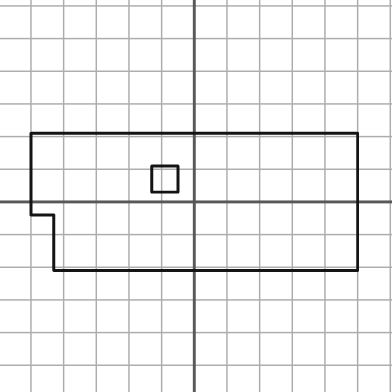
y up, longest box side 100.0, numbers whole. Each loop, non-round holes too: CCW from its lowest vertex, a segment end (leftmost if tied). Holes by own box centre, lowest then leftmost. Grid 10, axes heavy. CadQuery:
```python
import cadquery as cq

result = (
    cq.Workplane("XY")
    .moveTo(-43.0, -21.0)
    .lineTo(50.0, -21.0)
    .lineTo(50.0, 21.0)
    .lineTo(-50.0, 21.0)
    .lineTo(-50.0, -4.0)
    .lineTo(-43.0, -4.0)
    .close()
    .moveTo(-13.0, 3.0)
    .lineTo(-5.0, 3.0)
    .lineTo(-5.0, 11.0)
    .lineTo(-13.0, 11.0)
    .close()
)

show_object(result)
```